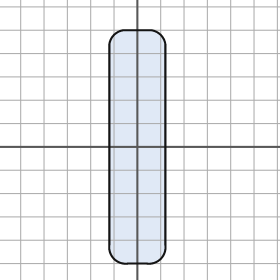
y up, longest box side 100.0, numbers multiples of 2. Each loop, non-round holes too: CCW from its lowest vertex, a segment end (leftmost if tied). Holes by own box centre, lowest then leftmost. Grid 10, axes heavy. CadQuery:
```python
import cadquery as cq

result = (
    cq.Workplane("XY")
    .moveTo(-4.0, -50.0)
    .lineTo(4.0, -50.0)
    .threePointArc((10.0, -48.0), (12.0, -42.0))
    .lineTo(12.0, 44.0)
    .threePointArc((10.0, 48.0), (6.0, 50.0))
    .lineTo(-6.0, 50.0)
    .threePointArc((-10.0, 48.0), (-12.0, 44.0))
    .lineTo(-12.0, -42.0)
    .threePointArc((-10.0, -48.0), (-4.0, -50.0))
    .close()
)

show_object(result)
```